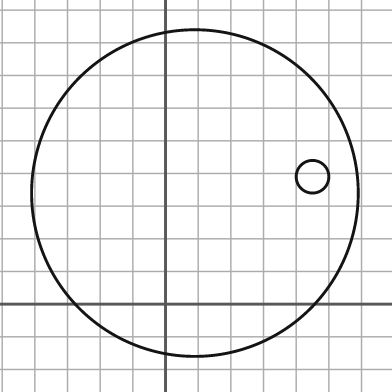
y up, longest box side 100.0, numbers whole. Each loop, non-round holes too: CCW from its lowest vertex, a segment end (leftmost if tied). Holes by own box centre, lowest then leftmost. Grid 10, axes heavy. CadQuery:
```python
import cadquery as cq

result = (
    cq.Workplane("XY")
    .moveTo(9.0, 34.0)
    .circle(50.0)
    .moveTo(45.0, 39.0)
    .circle(5.0)
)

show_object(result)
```